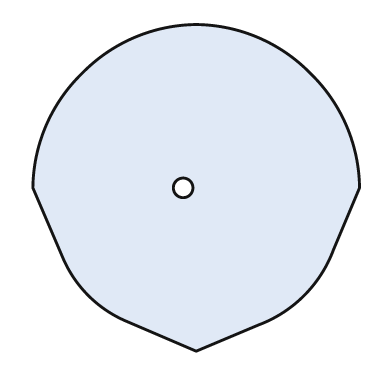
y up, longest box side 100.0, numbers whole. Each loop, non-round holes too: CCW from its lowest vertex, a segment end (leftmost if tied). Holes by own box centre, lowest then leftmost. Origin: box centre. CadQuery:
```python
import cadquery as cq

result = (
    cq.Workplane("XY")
    .moveTo(0.0, -50.0)
    .lineTo(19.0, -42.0)
    .threePointArc((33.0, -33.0), (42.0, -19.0))
    .lineTo(50.0, 0.0)
    .threePointArc((46.0, 19.0), (35.0, 35.0))
    .threePointArc((19.0, 46.0), (0.0, 50.0))
    .threePointArc((-19.0, 46.0), (-35.0, 35.0))
    .threePointArc((-46.0, 19.0), (-50.0, 0.0))
    .lineTo(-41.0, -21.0)
    .threePointArc((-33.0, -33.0), (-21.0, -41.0))
    .close()
    .moveTo(-4.0, 0.0)
    .circle(3.0)
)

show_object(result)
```